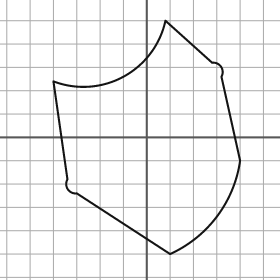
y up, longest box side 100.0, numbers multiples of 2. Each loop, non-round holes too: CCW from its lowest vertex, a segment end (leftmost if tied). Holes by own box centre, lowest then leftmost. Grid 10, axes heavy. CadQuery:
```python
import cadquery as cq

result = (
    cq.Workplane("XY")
    .moveTo(10.0, -50.0)
    .threePointArc((30.0, -34.0), (40.0, -10.0))
    .lineTo(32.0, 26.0)
    .threePointArc((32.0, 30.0), (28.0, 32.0))
    .lineTo(8.0, 50.0)
    .threePointArc((-10.0, 26.0), (-40.0, 24.0))
    .lineTo(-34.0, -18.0)
    .threePointArc((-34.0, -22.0), (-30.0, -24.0))
    .close()
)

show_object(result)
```